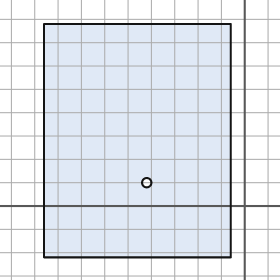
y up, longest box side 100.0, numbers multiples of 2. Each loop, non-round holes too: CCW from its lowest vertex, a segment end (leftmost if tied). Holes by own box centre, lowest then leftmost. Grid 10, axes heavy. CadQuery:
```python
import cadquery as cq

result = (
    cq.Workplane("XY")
    .moveTo(-86.0, -22.0)
    .lineTo(-6.0, -22.0)
    .lineTo(-6.0, 78.0)
    .lineTo(-86.0, 78.0)
    .close()
    .moveTo(-42.0, 10.0)
    .circle(2.0)
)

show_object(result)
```